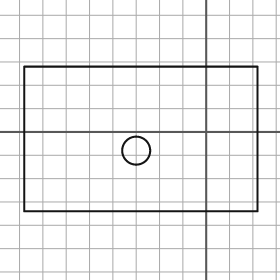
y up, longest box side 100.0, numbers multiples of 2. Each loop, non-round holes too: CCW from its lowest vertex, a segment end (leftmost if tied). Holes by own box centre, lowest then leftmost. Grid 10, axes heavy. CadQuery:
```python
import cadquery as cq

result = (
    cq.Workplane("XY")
    .moveTo(-78.0, -34.0)
    .lineTo(22.0, -34.0)
    .lineTo(22.0, 28.0)
    .lineTo(-78.0, 28.0)
    .close()
    .moveTo(-30.0, -8.0)
    .circle(6.0)
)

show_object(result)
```